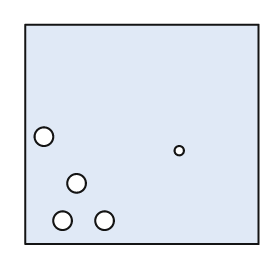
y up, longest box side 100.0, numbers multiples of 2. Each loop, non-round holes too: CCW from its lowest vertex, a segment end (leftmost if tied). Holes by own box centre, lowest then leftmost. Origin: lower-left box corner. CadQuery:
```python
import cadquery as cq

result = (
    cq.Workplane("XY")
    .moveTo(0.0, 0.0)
    .lineTo(100.0, 0.0)
    .lineTo(100.0, 94.0)
    .lineTo(0.0, 94.0)
    .close()
    .moveTo(16.0, 10.0)
    .circle(4.0)
    .moveTo(34.0, 10.0)
    .circle(4.0)
    .moveTo(22.0, 26.0)
    .circle(4.0)
    .moveTo(66.0, 40.0)
    .circle(2.0)
    .moveTo(8.0, 46.0)
    .circle(4.0)
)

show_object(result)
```